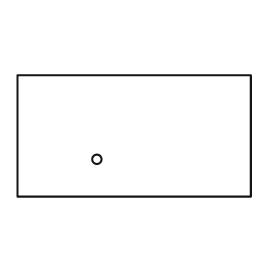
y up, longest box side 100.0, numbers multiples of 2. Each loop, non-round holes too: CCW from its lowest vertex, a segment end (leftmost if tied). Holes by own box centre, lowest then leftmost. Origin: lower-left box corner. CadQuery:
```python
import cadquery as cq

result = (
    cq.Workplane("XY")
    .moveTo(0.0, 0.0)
    .lineTo(100.0, 0.0)
    .lineTo(100.0, 52.0)
    .lineTo(0.0, 52.0)
    .close()
    .moveTo(34.0, 16.0)
    .circle(2.0)
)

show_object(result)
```